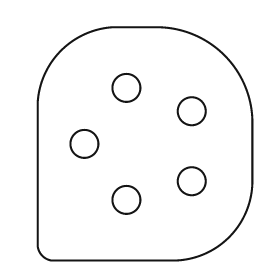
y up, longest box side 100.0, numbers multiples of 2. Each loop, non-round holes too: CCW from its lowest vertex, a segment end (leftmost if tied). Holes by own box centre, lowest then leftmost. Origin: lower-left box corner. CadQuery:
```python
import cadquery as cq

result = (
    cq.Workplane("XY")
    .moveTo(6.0, 0.0)
    .lineTo(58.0, 0.0)
    .threePointArc((82.0, 10.0), (92.0, 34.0))
    .lineTo(92.0, 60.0)
    .threePointArc((80.0, 88.0), (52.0, 100.0))
    .lineTo(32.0, 100.0)
    .threePointArc((10.0, 90.0), (0.0, 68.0))
    .lineTo(0.0, 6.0)
    .threePointArc((2.0, 2.0), (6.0, 0.0))
    .close()
    .moveTo(38.0, 26.0)
    .circle(6.0)
    .moveTo(66.0, 34.0)
    .circle(6.0)
    .moveTo(20.0, 50.0)
    .circle(6.0)
    .moveTo(66.0, 64.0)
    .circle(6.0)
    .moveTo(38.0, 74.0)
    .circle(6.0)
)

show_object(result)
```